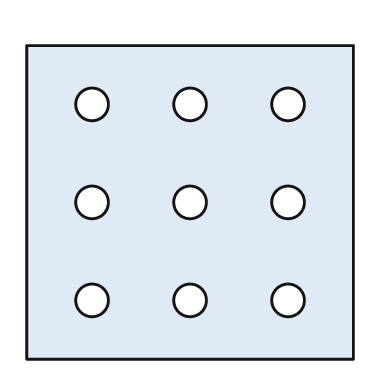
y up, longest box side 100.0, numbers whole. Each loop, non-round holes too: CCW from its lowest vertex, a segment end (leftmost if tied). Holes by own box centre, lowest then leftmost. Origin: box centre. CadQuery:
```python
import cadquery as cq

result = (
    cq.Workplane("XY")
    .moveTo(-50.0, -48.0)
    .lineTo(50.0, -48.0)
    .lineTo(50.0, 48.0)
    .lineTo(-50.0, 48.0)
    .close()
    .moveTo(-30.0, -30.0)
    .circle(5.0)
    .moveTo(0.0, -30.0)
    .circle(5.0)
    .moveTo(30.0, -30.0)
    .circle(5.0)
    .moveTo(-30.0, 0.0)
    .circle(5.0)
    .moveTo(0.0, 0.0)
    .circle(5.0)
    .moveTo(30.0, 0.0)
    .circle(5.0)
    .moveTo(-30.0, 30.0)
    .circle(5.0)
    .moveTo(0.0, 30.0)
    .circle(5.0)
    .moveTo(30.0, 30.0)
    .circle(5.0)
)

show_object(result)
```